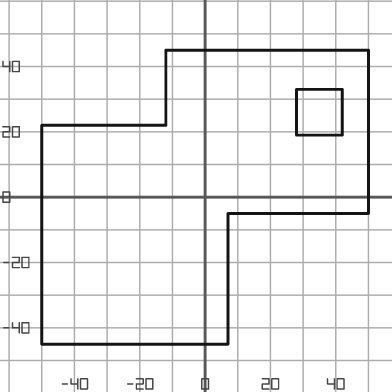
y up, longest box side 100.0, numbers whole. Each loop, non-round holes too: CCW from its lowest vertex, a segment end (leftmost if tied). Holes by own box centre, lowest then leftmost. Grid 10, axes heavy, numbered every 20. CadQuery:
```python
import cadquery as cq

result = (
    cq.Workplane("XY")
    .moveTo(-50.0, -45.0)
    .lineTo(7.0, -45.0)
    .lineTo(7.0, -5.0)
    .lineTo(50.0, -5.0)
    .lineTo(50.0, 45.0)
    .lineTo(-12.0, 45.0)
    .lineTo(-12.0, 22.0)
    .lineTo(-50.0, 22.0)
    .close()
    .moveTo(28.0, 19.0)
    .lineTo(42.0, 19.0)
    .lineTo(42.0, 33.0)
    .lineTo(28.0, 33.0)
    .close()
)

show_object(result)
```